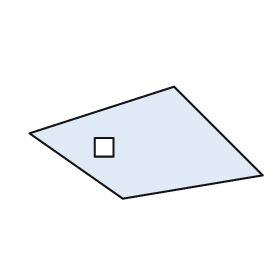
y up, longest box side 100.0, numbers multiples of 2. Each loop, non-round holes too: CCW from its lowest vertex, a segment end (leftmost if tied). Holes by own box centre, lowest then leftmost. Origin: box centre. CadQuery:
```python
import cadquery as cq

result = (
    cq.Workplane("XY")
    .moveTo(-10.0, -24.0)
    .lineTo(50.0, -14.0)
    .lineTo(12.0, 24.0)
    .lineTo(-50.0, 4.0)
    .close()
    .moveTo(-22.0, -6.0)
    .lineTo(-14.0, -6.0)
    .lineTo(-14.0, 2.0)
    .lineTo(-22.0, 2.0)
    .close()
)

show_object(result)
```